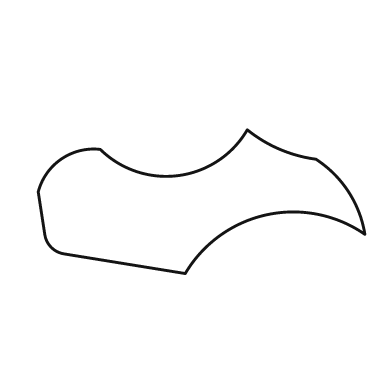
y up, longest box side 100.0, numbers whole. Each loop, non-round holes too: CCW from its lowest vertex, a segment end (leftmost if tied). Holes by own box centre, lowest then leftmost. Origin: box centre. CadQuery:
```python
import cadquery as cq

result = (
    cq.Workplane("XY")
    .moveTo(-5.0, -22.0)
    .threePointArc((20.0, -4.0), (50.0, -10.0))
    .threePointArc((45.0, 3.0), (35.0, 13.0))
    .threePointArc((24.0, 16.0), (14.0, 22.0))
    .threePointArc((-7.0, 8.0), (-31.0, 16.0))
    .threePointArc((-43.0, 13.0), (-50.0, 3.0))
    .lineTo(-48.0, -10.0)
    .threePointArc((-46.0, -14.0), (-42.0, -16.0))
    .close()
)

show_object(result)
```